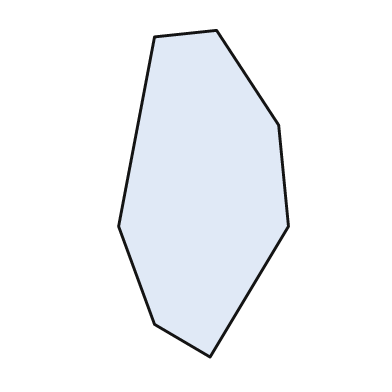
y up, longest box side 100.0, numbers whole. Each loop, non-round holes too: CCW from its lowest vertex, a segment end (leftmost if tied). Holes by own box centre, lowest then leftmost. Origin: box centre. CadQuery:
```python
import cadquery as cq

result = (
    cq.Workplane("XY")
    .moveTo(2.0, -50.0)
    .lineTo(26.0, -10.0)
    .lineTo(23.0, 21.0)
    .lineTo(4.0, 50.0)
    .lineTo(-15.0, 48.0)
    .lineTo(-26.0, -10.0)
    .lineTo(-15.0, -40.0)
    .close()
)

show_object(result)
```